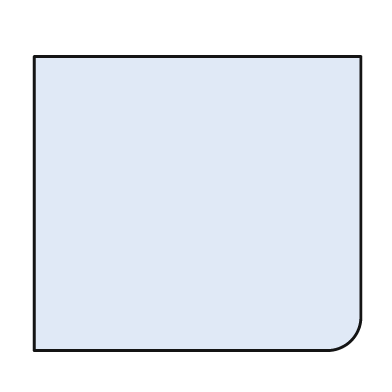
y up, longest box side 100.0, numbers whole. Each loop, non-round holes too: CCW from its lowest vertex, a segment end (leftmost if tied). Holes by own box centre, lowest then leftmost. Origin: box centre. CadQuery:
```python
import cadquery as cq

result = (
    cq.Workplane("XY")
    .moveTo(-50.0, -45.0)
    .lineTo(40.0, -45.0)
    .threePointArc((47.0, -42.0), (50.0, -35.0))
    .lineTo(50.0, 45.0)
    .lineTo(-50.0, 45.0)
    .close()
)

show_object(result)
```